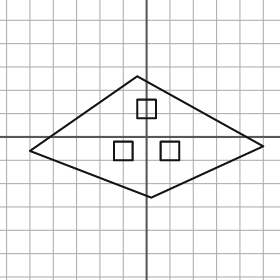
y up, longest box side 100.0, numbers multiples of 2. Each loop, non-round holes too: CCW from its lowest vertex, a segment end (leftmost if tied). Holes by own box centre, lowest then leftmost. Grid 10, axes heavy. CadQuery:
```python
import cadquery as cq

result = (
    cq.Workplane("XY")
    .moveTo(2.0, -26.0)
    .lineTo(50.0, -4.0)
    .lineTo(-4.0, 26.0)
    .lineTo(-50.0, -6.0)
    .close()
    .moveTo(-14.0, -10.0)
    .lineTo(-6.0, -10.0)
    .lineTo(-6.0, -2.0)
    .lineTo(-14.0, -2.0)
    .close()
    .moveTo(6.0, -10.0)
    .lineTo(14.0, -10.0)
    .lineTo(14.0, -2.0)
    .lineTo(6.0, -2.0)
    .close()
    .moveTo(-4.0, 8.0)
    .lineTo(4.0, 8.0)
    .lineTo(4.0, 16.0)
    .lineTo(-4.0, 16.0)
    .close()
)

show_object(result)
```